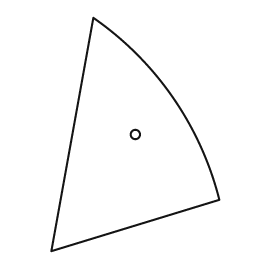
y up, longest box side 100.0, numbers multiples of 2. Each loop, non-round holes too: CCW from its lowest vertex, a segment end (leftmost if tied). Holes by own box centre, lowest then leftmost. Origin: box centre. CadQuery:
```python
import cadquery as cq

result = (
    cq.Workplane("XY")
    .moveTo(-36.0, -50.0)
    .lineTo(36.0, -28.0)
    .threePointArc((16.0, 16.0), (-18.0, 50.0))
    .close()
    .moveTo(0.0, 0.0)
    .circle(2.0)
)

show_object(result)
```